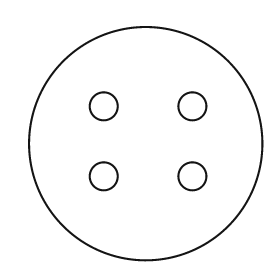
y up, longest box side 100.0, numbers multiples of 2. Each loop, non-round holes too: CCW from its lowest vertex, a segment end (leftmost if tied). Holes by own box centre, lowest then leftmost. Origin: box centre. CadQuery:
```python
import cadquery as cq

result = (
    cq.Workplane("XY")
    .moveTo(0.0, 0.0)
    .circle(50.0)
    .moveTo(-18.0, -14.0)
    .circle(6.0)
    .moveTo(20.0, -14.0)
    .circle(6.0)
    .moveTo(-18.0, 16.0)
    .circle(6.0)
    .moveTo(20.0, 16.0)
    .circle(6.0)
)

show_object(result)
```